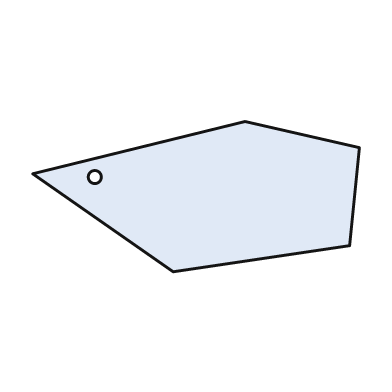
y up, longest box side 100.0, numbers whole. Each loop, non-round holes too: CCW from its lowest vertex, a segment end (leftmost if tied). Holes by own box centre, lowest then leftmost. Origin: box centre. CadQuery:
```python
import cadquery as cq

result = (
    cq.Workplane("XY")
    .moveTo(-7.0, -23.0)
    .lineTo(47.0, -15.0)
    .lineTo(50.0, 15.0)
    .lineTo(15.0, 23.0)
    .lineTo(-50.0, 7.0)
    .close()
    .moveTo(-31.0, 6.0)
    .circle(2.0)
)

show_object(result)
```